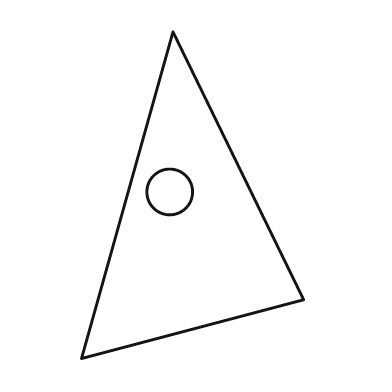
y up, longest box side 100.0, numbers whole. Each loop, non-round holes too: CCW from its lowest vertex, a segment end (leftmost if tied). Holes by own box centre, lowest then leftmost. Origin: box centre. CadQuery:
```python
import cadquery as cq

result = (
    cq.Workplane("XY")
    .moveTo(-34.0, -50.0)
    .lineTo(34.0, -32.0)
    .lineTo(-6.0, 50.0)
    .close()
    .moveTo(-7.0, 1.0)
    .circle(7.0)
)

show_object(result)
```